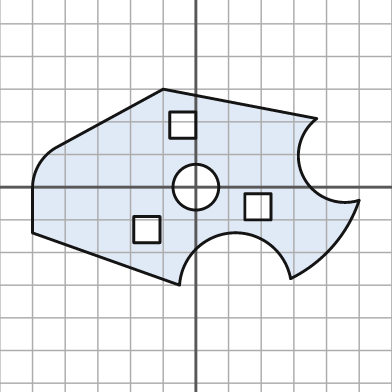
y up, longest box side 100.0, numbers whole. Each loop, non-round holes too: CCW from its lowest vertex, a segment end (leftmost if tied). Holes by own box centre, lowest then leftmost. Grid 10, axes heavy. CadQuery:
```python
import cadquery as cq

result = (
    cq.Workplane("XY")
    .moveTo(-5.0, -30.0)
    .threePointArc((11.0, -14.0), (29.0, -28.0))
    .threePointArc((42.0, -18.0), (50.0, -4.0))
    .threePointArc((33.0, 3.0), (37.0, 21.0))
    .lineTo(-10.0, 30.0)
    .lineTo(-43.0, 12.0)
    .threePointArc((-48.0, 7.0), (-50.0, 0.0))
    .lineTo(-50.0, -14.0)
    .close()
    .moveTo(-19.0, -17.0)
    .lineTo(-11.0, -17.0)
    .lineTo(-11.0, -9.0)
    .lineTo(-19.0, -9.0)
    .close()
    .moveTo(15.0, -10.0)
    .lineTo(23.0, -10.0)
    .lineTo(23.0, -2.0)
    .lineTo(15.0, -2.0)
    .close()
    .moveTo(0.0, 0.0)
    .circle(7.0)
    .moveTo(-8.0, 15.0)
    .lineTo(0.0, 15.0)
    .lineTo(0.0, 23.0)
    .lineTo(-8.0, 23.0)
    .close()
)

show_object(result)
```